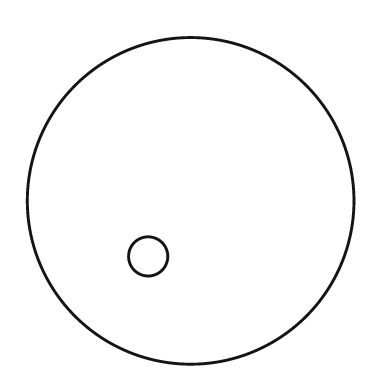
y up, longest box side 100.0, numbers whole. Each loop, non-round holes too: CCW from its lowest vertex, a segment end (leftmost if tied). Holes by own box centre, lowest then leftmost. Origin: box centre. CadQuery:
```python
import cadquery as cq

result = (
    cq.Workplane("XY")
    .moveTo(0.0, 0.0)
    .circle(50.0)
    .moveTo(-13.0, -17.0)
    .circle(6.0)
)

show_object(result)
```